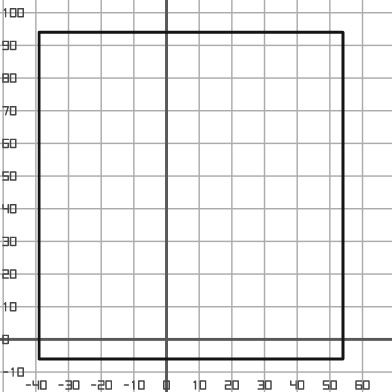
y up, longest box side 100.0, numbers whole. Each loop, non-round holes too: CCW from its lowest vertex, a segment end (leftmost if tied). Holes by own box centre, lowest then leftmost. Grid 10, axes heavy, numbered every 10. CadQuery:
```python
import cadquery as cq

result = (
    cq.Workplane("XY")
    .moveTo(-39.0, -6.0)
    .lineTo(54.0, -6.0)
    .lineTo(54.0, 94.0)
    .lineTo(-39.0, 94.0)
    .close()
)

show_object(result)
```